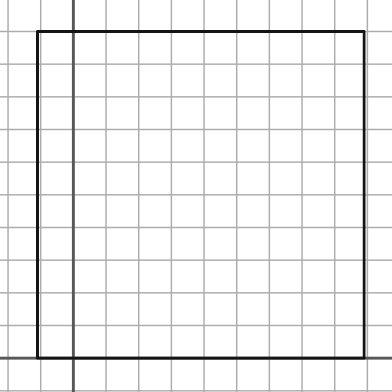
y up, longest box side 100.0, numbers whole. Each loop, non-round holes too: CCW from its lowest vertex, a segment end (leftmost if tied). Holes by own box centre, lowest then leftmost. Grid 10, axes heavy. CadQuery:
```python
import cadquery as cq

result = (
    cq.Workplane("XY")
    .moveTo(-11.0, 0.0)
    .lineTo(89.0, 0.0)
    .lineTo(89.0, 100.0)
    .lineTo(-11.0, 100.0)
    .close()
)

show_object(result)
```